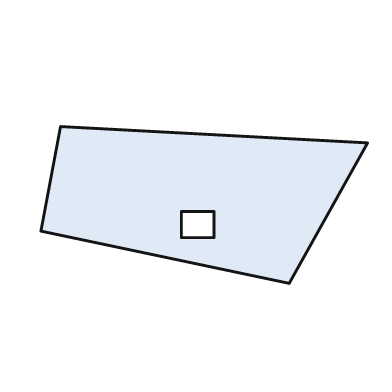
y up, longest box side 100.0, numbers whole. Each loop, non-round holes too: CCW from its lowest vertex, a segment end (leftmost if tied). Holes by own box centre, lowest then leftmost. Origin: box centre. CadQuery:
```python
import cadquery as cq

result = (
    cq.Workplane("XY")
    .moveTo(26.0, -24.0)
    .lineTo(50.0, 19.0)
    .lineTo(-44.0, 24.0)
    .lineTo(-50.0, -8.0)
    .close()
    .moveTo(-7.0, -10.0)
    .lineTo(3.0, -10.0)
    .lineTo(3.0, -2.0)
    .lineTo(-7.0, -2.0)
    .close()
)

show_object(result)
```